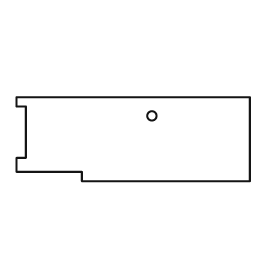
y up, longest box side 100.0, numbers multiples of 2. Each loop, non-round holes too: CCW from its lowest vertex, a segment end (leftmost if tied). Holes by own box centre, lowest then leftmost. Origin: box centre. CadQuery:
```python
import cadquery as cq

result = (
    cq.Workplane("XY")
    .moveTo(-22.0, -18.0)
    .lineTo(50.0, -18.0)
    .lineTo(50.0, 18.0)
    .lineTo(-50.0, 18.0)
    .lineTo(-50.0, 14.0)
    .lineTo(-46.0, 14.0)
    .lineTo(-46.0, -8.0)
    .lineTo(-50.0, -8.0)
    .lineTo(-50.0, -14.0)
    .lineTo(-22.0, -14.0)
    .close()
    .moveTo(8.0, 10.0)
    .circle(2.0)
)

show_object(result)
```